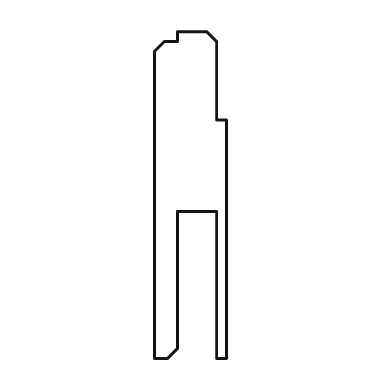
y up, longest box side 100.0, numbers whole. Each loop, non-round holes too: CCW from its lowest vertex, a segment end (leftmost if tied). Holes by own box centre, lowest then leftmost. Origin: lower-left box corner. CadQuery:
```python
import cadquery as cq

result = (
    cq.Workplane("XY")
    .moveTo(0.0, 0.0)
    .lineTo(4.0, 0.0)
    .lineTo(7.0, 3.0)
    .lineTo(7.0, 45.0)
    .lineTo(19.0, 45.0)
    .lineTo(19.0, 0.0)
    .lineTo(22.0, 0.0)
    .lineTo(22.0, 73.0)
    .lineTo(19.0, 73.0)
    .lineTo(19.0, 97.0)
    .lineTo(16.0, 100.0)
    .lineTo(7.0, 100.0)
    .lineTo(7.0, 97.0)
    .lineTo(3.0, 97.0)
    .lineTo(0.0, 94.0)
    .close()
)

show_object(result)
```